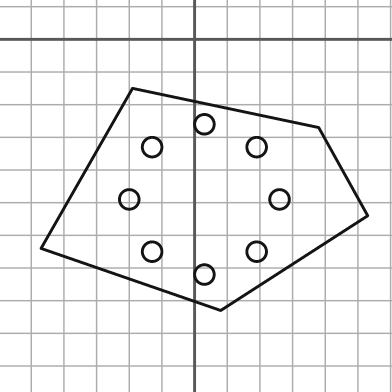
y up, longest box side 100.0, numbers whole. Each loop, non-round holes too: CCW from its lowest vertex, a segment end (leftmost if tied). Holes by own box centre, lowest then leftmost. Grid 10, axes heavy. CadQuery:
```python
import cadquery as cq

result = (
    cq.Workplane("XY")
    .moveTo(8.0, -83.0)
    .lineTo(53.0, -54.0)
    .lineTo(38.0, -27.0)
    .lineTo(-19.0, -15.0)
    .lineTo(-47.0, -64.0)
    .close()
    .moveTo(3.0, -72.0)
    .circle(3.0)
    .moveTo(-13.0, -65.0)
    .circle(3.0)
    .moveTo(19.0, -65.0)
    .circle(3.0)
    .moveTo(-20.0, -49.0)
    .circle(3.0)
    .moveTo(26.0, -49.0)
    .circle(3.0)
    .moveTo(-13.0, -33.0)
    .circle(3.0)
    .moveTo(19.0, -33.0)
    .circle(3.0)
    .moveTo(3.0, -26.0)
    .circle(3.0)
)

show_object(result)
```